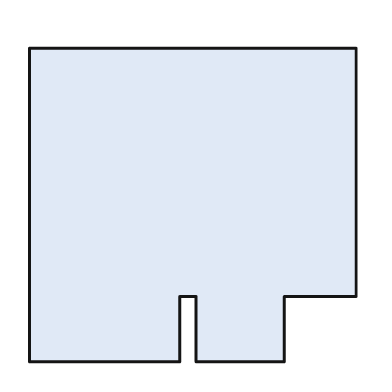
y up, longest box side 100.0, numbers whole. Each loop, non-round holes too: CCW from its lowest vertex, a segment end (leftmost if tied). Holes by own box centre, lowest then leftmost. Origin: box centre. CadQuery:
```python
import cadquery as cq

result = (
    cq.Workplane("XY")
    .moveTo(-50.0, -48.0)
    .lineTo(-4.0, -48.0)
    .lineTo(-4.0, -28.0)
    .lineTo(1.0, -28.0)
    .lineTo(1.0, -48.0)
    .lineTo(28.0, -48.0)
    .lineTo(28.0, -28.0)
    .lineTo(50.0, -28.0)
    .lineTo(50.0, 48.0)
    .lineTo(-50.0, 48.0)
    .close()
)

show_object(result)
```